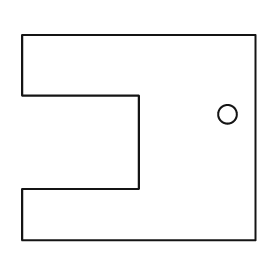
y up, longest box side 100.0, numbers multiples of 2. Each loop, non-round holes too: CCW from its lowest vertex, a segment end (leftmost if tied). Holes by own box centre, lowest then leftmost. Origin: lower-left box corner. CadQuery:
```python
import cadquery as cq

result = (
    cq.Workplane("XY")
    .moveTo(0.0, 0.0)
    .lineTo(100.0, 0.0)
    .lineTo(100.0, 88.0)
    .lineTo(0.0, 88.0)
    .lineTo(0.0, 62.0)
    .lineTo(50.0, 62.0)
    .lineTo(50.0, 22.0)
    .lineTo(0.0, 22.0)
    .close()
    .moveTo(88.0, 54.0)
    .circle(4.0)
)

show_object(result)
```